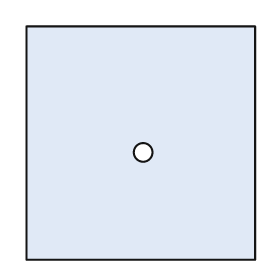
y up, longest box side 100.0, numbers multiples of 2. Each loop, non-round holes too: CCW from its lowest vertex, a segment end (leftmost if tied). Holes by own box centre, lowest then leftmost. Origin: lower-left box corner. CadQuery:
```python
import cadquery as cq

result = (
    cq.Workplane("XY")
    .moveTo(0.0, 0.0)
    .lineTo(98.0, 0.0)
    .lineTo(98.0, 100.0)
    .lineTo(0.0, 100.0)
    .close()
    .moveTo(50.0, 46.0)
    .circle(4.0)
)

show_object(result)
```